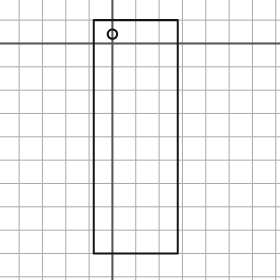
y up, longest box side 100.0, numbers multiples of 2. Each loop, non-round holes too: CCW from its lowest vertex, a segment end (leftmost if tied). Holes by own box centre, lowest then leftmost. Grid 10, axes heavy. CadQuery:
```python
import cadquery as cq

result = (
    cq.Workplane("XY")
    .moveTo(-8.0, -90.0)
    .lineTo(28.0, -90.0)
    .lineTo(28.0, 10.0)
    .lineTo(-8.0, 10.0)
    .close()
    .moveTo(0.0, 4.0)
    .circle(2.0)
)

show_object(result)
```